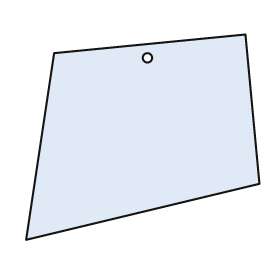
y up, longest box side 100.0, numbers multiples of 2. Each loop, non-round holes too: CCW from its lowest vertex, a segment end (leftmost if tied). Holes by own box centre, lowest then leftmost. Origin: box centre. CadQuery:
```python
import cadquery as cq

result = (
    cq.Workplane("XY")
    .moveTo(-50.0, -44.0)
    .lineTo(50.0, -20.0)
    .lineTo(44.0, 44.0)
    .lineTo(-38.0, 36.0)
    .close()
    .moveTo(2.0, 34.0)
    .circle(2.0)
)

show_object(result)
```